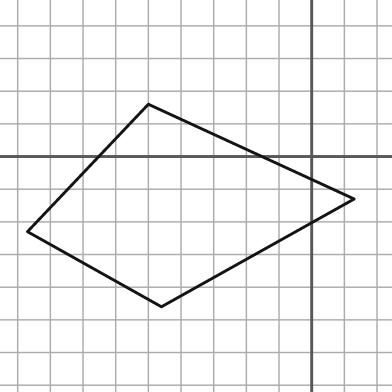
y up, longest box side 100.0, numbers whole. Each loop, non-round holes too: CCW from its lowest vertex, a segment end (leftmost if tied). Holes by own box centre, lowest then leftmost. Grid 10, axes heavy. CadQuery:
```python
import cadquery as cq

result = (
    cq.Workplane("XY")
    .moveTo(-46.0, -46.0)
    .lineTo(13.0, -13.0)
    .lineTo(-50.0, 16.0)
    .lineTo(-87.0, -23.0)
    .close()
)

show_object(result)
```